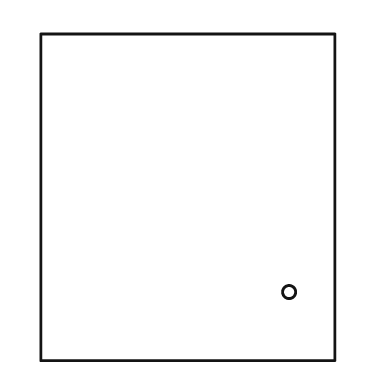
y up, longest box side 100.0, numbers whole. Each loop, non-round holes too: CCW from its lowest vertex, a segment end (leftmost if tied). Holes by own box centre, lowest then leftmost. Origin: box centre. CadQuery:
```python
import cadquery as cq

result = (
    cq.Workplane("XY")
    .moveTo(-45.0, -50.0)
    .lineTo(45.0, -50.0)
    .lineTo(45.0, 50.0)
    .lineTo(-45.0, 50.0)
    .close()
    .moveTo(31.0, -29.0)
    .circle(2.0)
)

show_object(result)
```